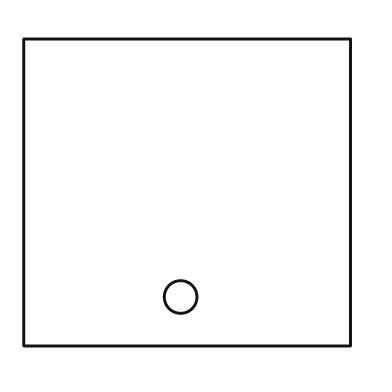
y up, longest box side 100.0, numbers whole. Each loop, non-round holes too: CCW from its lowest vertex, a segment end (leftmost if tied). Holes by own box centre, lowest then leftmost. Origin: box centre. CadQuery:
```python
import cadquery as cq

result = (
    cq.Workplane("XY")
    .moveTo(-50.0, -47.0)
    .lineTo(50.0, -47.0)
    .lineTo(50.0, 47.0)
    .lineTo(-50.0, 47.0)
    .close()
    .moveTo(-2.0, -32.0)
    .circle(5.0)
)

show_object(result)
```